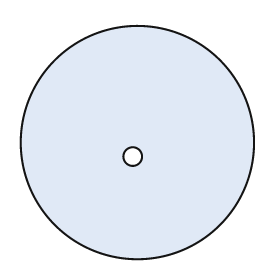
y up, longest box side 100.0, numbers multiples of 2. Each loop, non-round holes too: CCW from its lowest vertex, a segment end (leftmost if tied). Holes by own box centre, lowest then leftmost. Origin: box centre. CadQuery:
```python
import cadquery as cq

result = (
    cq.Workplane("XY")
    .moveTo(0.0, 0.0)
    .circle(50.0)
    .moveTo(-2.0, -6.0)
    .circle(4.0)
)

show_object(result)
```